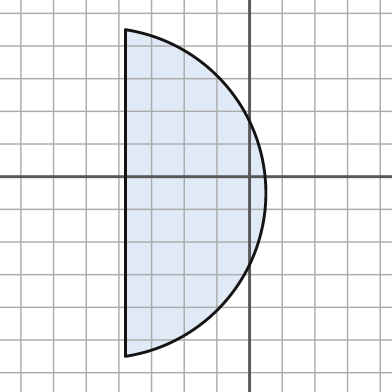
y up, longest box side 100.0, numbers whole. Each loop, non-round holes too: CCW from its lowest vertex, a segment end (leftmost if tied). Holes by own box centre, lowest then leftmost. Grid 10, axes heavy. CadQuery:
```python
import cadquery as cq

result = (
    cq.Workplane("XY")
    .moveTo(-38.0, -55.0)
    .threePointArc((5.0, -5.0), (-38.0, 45.0))
    .close()
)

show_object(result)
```